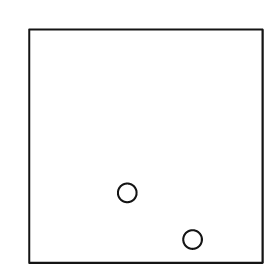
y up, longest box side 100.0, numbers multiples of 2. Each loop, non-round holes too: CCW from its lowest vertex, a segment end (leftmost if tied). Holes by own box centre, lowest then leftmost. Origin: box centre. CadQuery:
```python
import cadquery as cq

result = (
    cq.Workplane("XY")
    .moveTo(-50.0, -50.0)
    .lineTo(50.0, -50.0)
    .lineTo(50.0, 50.0)
    .lineTo(-50.0, 50.0)
    .close()
    .moveTo(20.0, -40.0)
    .circle(4.0)
    .moveTo(-8.0, -20.0)
    .circle(4.0)
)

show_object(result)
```